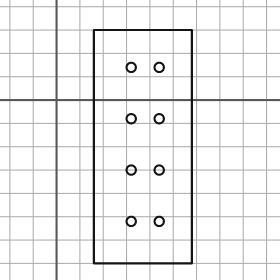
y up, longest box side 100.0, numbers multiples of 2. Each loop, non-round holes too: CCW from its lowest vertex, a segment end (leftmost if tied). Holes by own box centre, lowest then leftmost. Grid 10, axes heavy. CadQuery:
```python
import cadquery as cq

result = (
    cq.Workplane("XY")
    .moveTo(16.0, -70.0)
    .lineTo(58.0, -70.0)
    .lineTo(58.0, 30.0)
    .lineTo(16.0, 30.0)
    .close()
    .moveTo(32.0, -52.0)
    .circle(2.0)
    .moveTo(44.0, -52.0)
    .circle(2.0)
    .moveTo(32.0, -30.0)
    .circle(2.0)
    .moveTo(44.0, -30.0)
    .circle(2.0)
    .moveTo(32.0, -8.0)
    .circle(2.0)
    .moveTo(44.0, -8.0)
    .circle(2.0)
    .moveTo(32.0, 14.0)
    .circle(2.0)
    .moveTo(44.0, 14.0)
    .circle(2.0)
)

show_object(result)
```